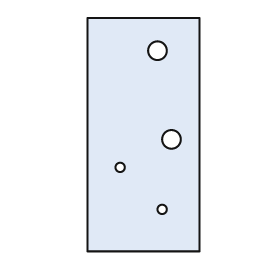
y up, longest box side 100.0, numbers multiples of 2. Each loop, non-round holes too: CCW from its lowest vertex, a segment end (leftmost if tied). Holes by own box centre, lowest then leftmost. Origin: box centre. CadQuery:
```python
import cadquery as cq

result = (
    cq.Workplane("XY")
    .moveTo(-24.0, -50.0)
    .lineTo(24.0, -50.0)
    .lineTo(24.0, 50.0)
    .lineTo(-24.0, 50.0)
    .close()
    .moveTo(8.0, -32.0)
    .circle(2.0)
    .moveTo(-10.0, -14.0)
    .circle(2.0)
    .moveTo(12.0, -2.0)
    .circle(4.0)
    .moveTo(6.0, 36.0)
    .circle(4.0)
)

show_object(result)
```